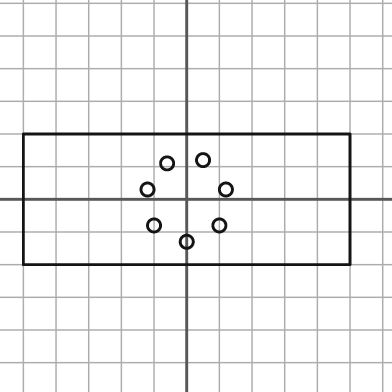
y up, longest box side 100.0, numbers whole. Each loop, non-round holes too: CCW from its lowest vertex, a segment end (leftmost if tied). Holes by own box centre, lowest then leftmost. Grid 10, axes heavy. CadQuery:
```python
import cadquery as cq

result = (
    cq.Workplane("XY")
    .moveTo(-50.0, -20.0)
    .lineTo(50.0, -20.0)
    .lineTo(50.0, 20.0)
    .lineTo(-50.0, 20.0)
    .close()
    .moveTo(0.0, -13.0)
    .circle(2.0)
    .moveTo(-10.0, -8.0)
    .circle(2.0)
    .moveTo(10.0, -8.0)
    .circle(2.0)
    .moveTo(-12.0, 3.0)
    .circle(2.0)
    .moveTo(12.0, 3.0)
    .circle(2.0)
    .moveTo(-6.0, 11.0)
    .circle(2.0)
    .moveTo(5.0, 12.0)
    .circle(2.0)
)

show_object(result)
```